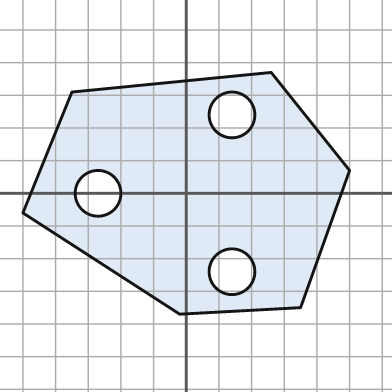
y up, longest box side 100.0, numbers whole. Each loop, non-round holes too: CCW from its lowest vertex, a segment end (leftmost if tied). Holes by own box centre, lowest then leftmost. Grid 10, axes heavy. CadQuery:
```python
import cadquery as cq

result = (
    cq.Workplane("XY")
    .moveTo(-2.0, -37.0)
    .lineTo(35.0, -35.0)
    .lineTo(50.0, 7.0)
    .lineTo(26.0, 37.0)
    .lineTo(-35.0, 31.0)
    .lineTo(-50.0, -6.0)
    .close()
    .moveTo(14.0, -24.0)
    .circle(7.0)
    .moveTo(-27.0, 0.0)
    .circle(7.0)
    .moveTo(14.0, 24.0)
    .circle(7.0)
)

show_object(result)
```